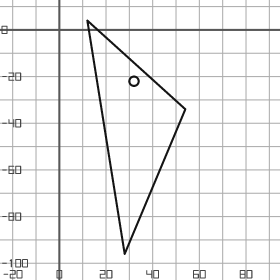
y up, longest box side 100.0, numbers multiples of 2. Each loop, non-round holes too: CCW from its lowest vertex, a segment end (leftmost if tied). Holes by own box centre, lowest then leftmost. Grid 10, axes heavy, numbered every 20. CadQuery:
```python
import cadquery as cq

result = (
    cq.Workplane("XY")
    .moveTo(28.0, -96.0)
    .lineTo(54.0, -34.0)
    .lineTo(12.0, 4.0)
    .close()
    .moveTo(32.0, -22.0)
    .circle(2.0)
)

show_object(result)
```